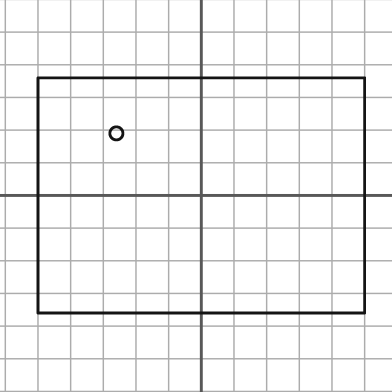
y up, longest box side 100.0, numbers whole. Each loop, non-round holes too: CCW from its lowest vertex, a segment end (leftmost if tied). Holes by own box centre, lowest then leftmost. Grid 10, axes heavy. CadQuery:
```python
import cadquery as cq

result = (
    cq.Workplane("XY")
    .moveTo(-50.0, -36.0)
    .lineTo(50.0, -36.0)
    .lineTo(50.0, 36.0)
    .lineTo(-50.0, 36.0)
    .close()
    .moveTo(-26.0, 19.0)
    .circle(2.0)
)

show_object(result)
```